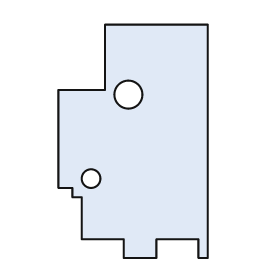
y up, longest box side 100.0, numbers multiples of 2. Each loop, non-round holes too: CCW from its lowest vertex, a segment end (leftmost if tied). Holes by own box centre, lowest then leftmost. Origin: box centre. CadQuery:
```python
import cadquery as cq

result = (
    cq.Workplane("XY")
    .moveTo(-4.0, -50.0)
    .lineTo(10.0, -50.0)
    .lineTo(10.0, -42.0)
    .lineTo(28.0, -42.0)
    .lineTo(28.0, -50.0)
    .lineTo(32.0, -50.0)
    .lineTo(32.0, 50.0)
    .lineTo(-12.0, 50.0)
    .lineTo(-12.0, 22.0)
    .lineTo(-32.0, 22.0)
    .lineTo(-32.0, -20.0)
    .lineTo(-26.0, -20.0)
    .lineTo(-26.0, -24.0)
    .lineTo(-22.0, -24.0)
    .lineTo(-22.0, -42.0)
    .lineTo(-4.0, -42.0)
    .close()
    .moveTo(-18.0, -16.0)
    .circle(4.0)
    .moveTo(-2.0, 20.0)
    .circle(6.0)
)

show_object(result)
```